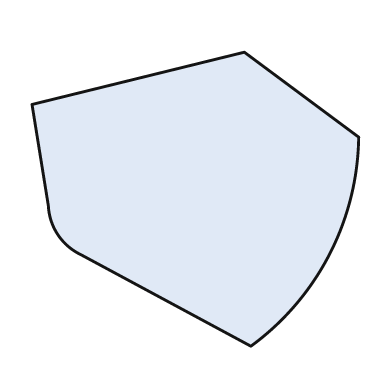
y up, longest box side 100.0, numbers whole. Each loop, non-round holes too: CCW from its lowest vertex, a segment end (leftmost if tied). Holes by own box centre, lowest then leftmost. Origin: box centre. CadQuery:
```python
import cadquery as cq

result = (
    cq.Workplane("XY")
    .moveTo(17.0, -45.0)
    .threePointArc((41.0, -17.0), (50.0, 19.0))
    .lineTo(15.0, 45.0)
    .lineTo(-50.0, 29.0)
    .lineTo(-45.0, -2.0)
    .threePointArc((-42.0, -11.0), (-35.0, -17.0))
    .close()
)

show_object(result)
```